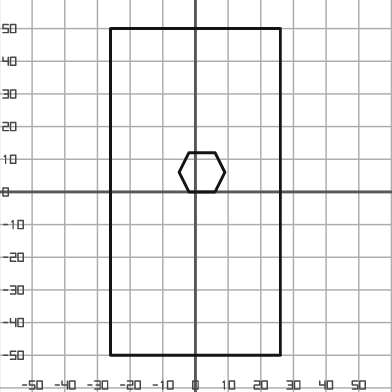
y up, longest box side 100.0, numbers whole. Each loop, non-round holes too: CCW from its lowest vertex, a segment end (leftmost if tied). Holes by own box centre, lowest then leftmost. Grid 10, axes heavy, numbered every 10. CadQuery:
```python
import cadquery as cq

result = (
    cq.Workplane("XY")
    .moveTo(-26.0, -50.0)
    .lineTo(26.0, -50.0)
    .lineTo(26.0, 50.0)
    .lineTo(-26.0, 50.0)
    .close()
    .moveTo(-2.0, 0.0)
    .lineTo(6.0, 0.0)
    .lineTo(9.0, 6.0)
    .lineTo(6.0, 12.0)
    .lineTo(-2.0, 12.0)
    .lineTo(-5.0, 6.0)
    .close()
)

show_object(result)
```